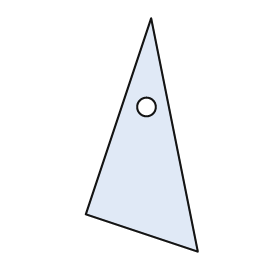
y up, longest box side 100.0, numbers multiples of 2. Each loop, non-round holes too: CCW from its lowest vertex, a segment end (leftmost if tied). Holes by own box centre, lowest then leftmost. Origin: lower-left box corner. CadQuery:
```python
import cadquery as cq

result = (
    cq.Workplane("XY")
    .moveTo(48.0, 0.0)
    .lineTo(28.0, 100.0)
    .lineTo(0.0, 16.0)
    .close()
    .moveTo(26.0, 62.0)
    .circle(4.0)
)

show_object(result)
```